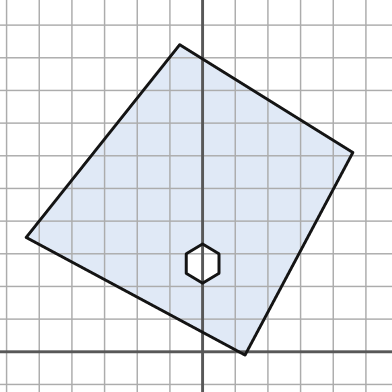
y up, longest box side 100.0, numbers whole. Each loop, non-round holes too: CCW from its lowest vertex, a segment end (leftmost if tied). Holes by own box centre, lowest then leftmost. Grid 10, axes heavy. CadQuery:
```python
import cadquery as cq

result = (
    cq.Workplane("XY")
    .moveTo(13.0, -1.0)
    .lineTo(46.0, 61.0)
    .lineTo(-7.0, 94.0)
    .lineTo(-54.0, 35.0)
    .close()
    .moveTo(0.0, 21.0)
    .lineTo(5.0, 24.0)
    .lineTo(5.0, 30.0)
    .lineTo(0.0, 33.0)
    .lineTo(-5.0, 30.0)
    .lineTo(-5.0, 24.0)
    .close()
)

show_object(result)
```